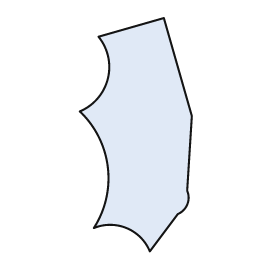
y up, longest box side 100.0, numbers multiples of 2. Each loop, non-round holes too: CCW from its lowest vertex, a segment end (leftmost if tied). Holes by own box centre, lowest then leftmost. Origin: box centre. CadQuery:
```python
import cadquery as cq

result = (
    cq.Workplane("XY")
    .moveTo(6.0, -50.0)
    .lineTo(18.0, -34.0)
    .threePointArc((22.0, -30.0), (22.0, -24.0))
    .lineTo(24.0, 8.0)
    .lineTo(12.0, 50.0)
    .lineTo(-16.0, 42.0)
    .threePointArc((-12.0, 24.0), (-24.0, 10.0))
    .threePointArc((-12.0, -14.0), (-18.0, -40.0))
    .threePointArc((-4.0, -40.0), (6.0, -50.0))
    .close()
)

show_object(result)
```